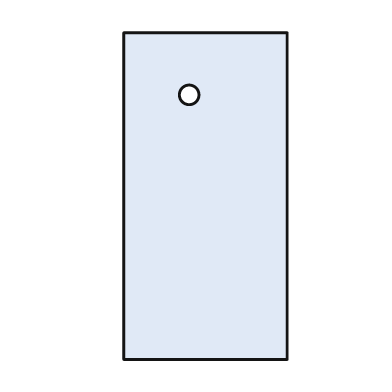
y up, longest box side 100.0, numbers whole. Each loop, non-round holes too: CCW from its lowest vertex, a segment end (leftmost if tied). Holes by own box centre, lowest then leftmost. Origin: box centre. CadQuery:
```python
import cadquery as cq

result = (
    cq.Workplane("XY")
    .moveTo(-25.0, -50.0)
    .lineTo(25.0, -50.0)
    .lineTo(25.0, 50.0)
    .lineTo(-25.0, 50.0)
    .close()
    .moveTo(-5.0, 31.0)
    .circle(3.0)
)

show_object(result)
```